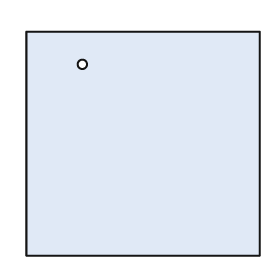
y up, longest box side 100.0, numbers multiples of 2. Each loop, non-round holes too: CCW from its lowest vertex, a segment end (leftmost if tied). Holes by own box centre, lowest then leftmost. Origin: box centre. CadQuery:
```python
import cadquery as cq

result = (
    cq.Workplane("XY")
    .moveTo(-50.0, -48.0)
    .lineTo(50.0, -48.0)
    .lineTo(50.0, 48.0)
    .lineTo(-50.0, 48.0)
    .close()
    .moveTo(-26.0, 34.0)
    .circle(2.0)
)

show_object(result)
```